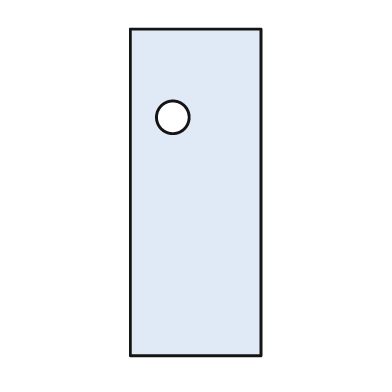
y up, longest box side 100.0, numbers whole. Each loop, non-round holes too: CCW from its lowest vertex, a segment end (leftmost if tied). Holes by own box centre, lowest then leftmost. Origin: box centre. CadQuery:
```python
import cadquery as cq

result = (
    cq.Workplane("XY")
    .moveTo(-20.0, -50.0)
    .lineTo(20.0, -50.0)
    .lineTo(20.0, 50.0)
    .lineTo(-20.0, 50.0)
    .close()
    .moveTo(-7.0, 23.0)
    .circle(5.0)
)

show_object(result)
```